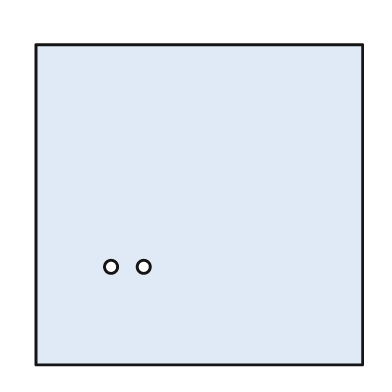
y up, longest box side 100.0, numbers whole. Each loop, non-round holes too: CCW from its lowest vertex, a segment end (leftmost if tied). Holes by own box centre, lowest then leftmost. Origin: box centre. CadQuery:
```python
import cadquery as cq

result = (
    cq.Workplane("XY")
    .moveTo(-50.0, -49.0)
    .lineTo(50.0, -49.0)
    .lineTo(50.0, 49.0)
    .lineTo(-50.0, 49.0)
    .close()
    .moveTo(-27.0, -19.0)
    .circle(2.0)
    .moveTo(-17.0, -19.0)
    .circle(2.0)
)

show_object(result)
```